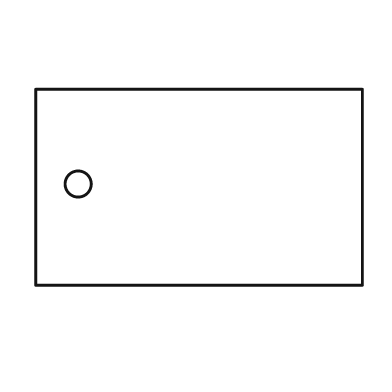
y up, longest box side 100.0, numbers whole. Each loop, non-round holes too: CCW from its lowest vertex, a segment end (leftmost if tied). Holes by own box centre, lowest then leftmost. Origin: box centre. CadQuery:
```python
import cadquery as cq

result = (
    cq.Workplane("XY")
    .moveTo(-50.0, -30.0)
    .lineTo(50.0, -30.0)
    .lineTo(50.0, 30.0)
    .lineTo(-50.0, 30.0)
    .close()
    .moveTo(-37.0, 1.0)
    .circle(4.0)
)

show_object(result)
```